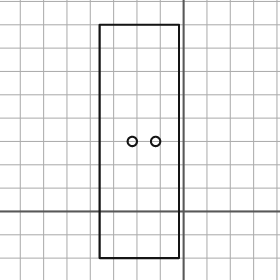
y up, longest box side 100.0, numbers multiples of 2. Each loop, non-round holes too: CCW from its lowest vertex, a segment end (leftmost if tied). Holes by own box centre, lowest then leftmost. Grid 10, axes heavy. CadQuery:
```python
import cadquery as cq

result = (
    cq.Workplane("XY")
    .moveTo(-36.0, -20.0)
    .lineTo(-2.0, -20.0)
    .lineTo(-2.0, 80.0)
    .lineTo(-36.0, 80.0)
    .close()
    .moveTo(-22.0, 30.0)
    .circle(2.0)
    .moveTo(-12.0, 30.0)
    .circle(2.0)
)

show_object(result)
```